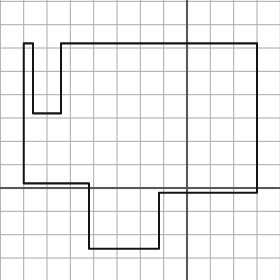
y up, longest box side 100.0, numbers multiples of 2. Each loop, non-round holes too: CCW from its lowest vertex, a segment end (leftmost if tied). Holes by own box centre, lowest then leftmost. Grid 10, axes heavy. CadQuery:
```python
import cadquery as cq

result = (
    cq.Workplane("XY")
    .moveTo(-42.0, -26.0)
    .lineTo(-12.0, -26.0)
    .lineTo(-12.0, -2.0)
    .lineTo(30.0, -2.0)
    .lineTo(30.0, 62.0)
    .lineTo(-54.0, 62.0)
    .lineTo(-54.0, 32.0)
    .lineTo(-66.0, 32.0)
    .lineTo(-66.0, 62.0)
    .lineTo(-70.0, 62.0)
    .lineTo(-70.0, 2.0)
    .lineTo(-42.0, 2.0)
    .close()
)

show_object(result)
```